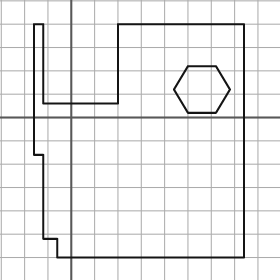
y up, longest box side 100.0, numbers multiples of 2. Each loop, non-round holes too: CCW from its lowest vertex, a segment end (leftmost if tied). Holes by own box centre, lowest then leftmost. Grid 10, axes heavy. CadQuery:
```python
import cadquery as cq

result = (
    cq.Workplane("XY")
    .moveTo(-6.0, -60.0)
    .lineTo(74.0, -60.0)
    .lineTo(74.0, 40.0)
    .lineTo(20.0, 40.0)
    .lineTo(20.0, 6.0)
    .lineTo(-12.0, 6.0)
    .lineTo(-12.0, 40.0)
    .lineTo(-16.0, 40.0)
    .lineTo(-16.0, -16.0)
    .lineTo(-12.0, -16.0)
    .lineTo(-12.0, -52.0)
    .lineTo(-6.0, -52.0)
    .close()
    .moveTo(50.0, 2.0)
    .lineTo(62.0, 2.0)
    .lineTo(68.0, 12.0)
    .lineTo(62.0, 22.0)
    .lineTo(50.0, 22.0)
    .lineTo(44.0, 12.0)
    .close()
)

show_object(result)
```